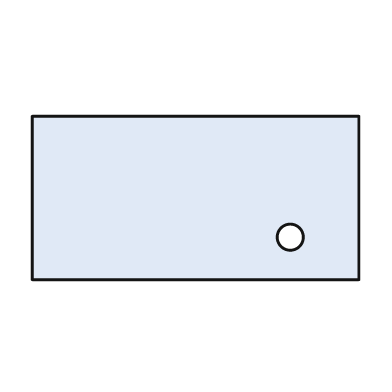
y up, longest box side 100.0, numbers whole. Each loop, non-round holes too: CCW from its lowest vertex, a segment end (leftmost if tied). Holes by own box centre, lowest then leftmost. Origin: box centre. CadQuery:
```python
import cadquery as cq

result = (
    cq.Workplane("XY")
    .moveTo(-50.0, -25.0)
    .lineTo(50.0, -25.0)
    .lineTo(50.0, 25.0)
    .lineTo(-50.0, 25.0)
    .close()
    .moveTo(29.0, -12.0)
    .circle(4.0)
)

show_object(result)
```